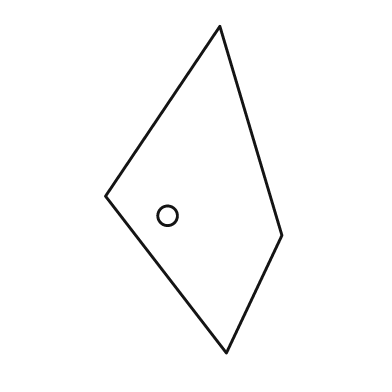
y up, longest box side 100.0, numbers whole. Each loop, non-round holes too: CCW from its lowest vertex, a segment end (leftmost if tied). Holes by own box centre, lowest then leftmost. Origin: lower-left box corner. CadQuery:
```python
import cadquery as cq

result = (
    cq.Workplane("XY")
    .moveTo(37.0, 0.0)
    .lineTo(54.0, 36.0)
    .lineTo(35.0, 100.0)
    .lineTo(0.0, 48.0)
    .close()
    .moveTo(19.0, 42.0)
    .circle(3.0)
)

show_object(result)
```